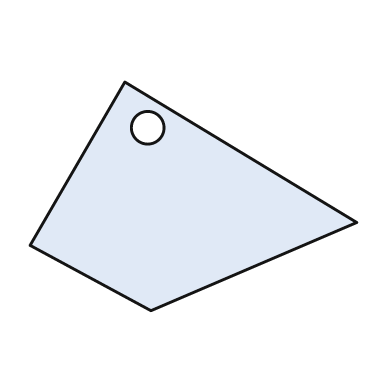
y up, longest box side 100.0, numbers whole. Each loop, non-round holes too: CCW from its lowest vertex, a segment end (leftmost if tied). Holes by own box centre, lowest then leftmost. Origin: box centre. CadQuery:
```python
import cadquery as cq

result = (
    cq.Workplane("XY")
    .moveTo(-13.0, -35.0)
    .lineTo(50.0, -8.0)
    .lineTo(-21.0, 35.0)
    .lineTo(-50.0, -15.0)
    .close()
    .moveTo(-14.0, 21.0)
    .circle(5.0)
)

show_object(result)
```